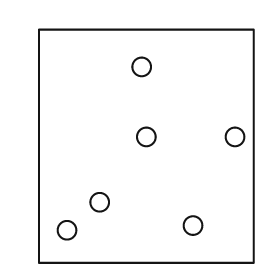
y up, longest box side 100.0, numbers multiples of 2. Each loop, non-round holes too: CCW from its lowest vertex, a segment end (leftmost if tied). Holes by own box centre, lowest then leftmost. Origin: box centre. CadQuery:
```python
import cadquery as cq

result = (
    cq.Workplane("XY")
    .moveTo(-46.0, -50.0)
    .lineTo(46.0, -50.0)
    .lineTo(46.0, 50.0)
    .lineTo(-46.0, 50.0)
    .close()
    .moveTo(-34.0, -36.0)
    .circle(4.0)
    .moveTo(20.0, -34.0)
    .circle(4.0)
    .moveTo(-20.0, -24.0)
    .circle(4.0)
    .moveTo(0.0, 4.0)
    .circle(4.0)
    .moveTo(38.0, 4.0)
    .circle(4.0)
    .moveTo(-2.0, 34.0)
    .circle(4.0)
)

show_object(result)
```